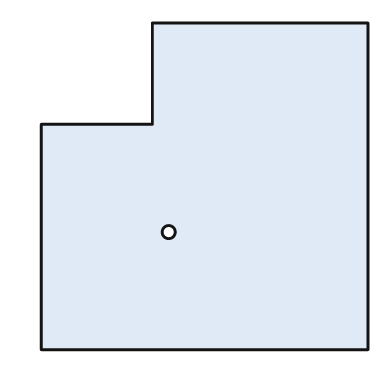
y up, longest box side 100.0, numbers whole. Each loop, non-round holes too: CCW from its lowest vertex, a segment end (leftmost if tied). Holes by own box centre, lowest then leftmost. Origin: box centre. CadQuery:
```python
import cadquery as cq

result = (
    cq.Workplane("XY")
    .moveTo(-50.0, -50.0)
    .lineTo(50.0, -50.0)
    .lineTo(50.0, 50.0)
    .lineTo(-16.0, 50.0)
    .lineTo(-16.0, 19.0)
    .lineTo(-50.0, 19.0)
    .close()
    .moveTo(-11.0, -14.0)
    .circle(2.0)
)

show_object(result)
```